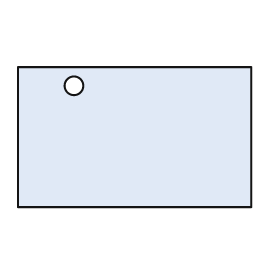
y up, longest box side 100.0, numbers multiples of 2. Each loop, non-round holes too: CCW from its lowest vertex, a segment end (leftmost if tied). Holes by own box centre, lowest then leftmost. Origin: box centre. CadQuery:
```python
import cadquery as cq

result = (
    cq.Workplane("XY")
    .moveTo(-50.0, -30.0)
    .lineTo(50.0, -30.0)
    .lineTo(50.0, 30.0)
    .lineTo(-50.0, 30.0)
    .close()
    .moveTo(-26.0, 22.0)
    .circle(4.0)
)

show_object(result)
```